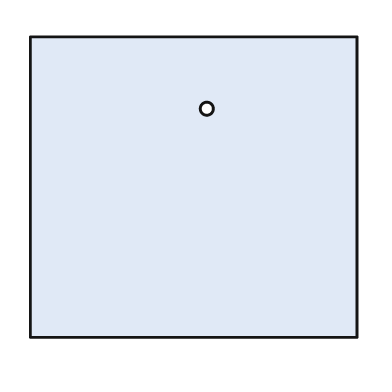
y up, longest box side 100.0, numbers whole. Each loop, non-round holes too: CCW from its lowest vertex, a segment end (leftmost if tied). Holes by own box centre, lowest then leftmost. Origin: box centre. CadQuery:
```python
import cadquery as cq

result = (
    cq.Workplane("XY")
    .moveTo(-50.0, -46.0)
    .lineTo(50.0, -46.0)
    .lineTo(50.0, 46.0)
    .lineTo(-50.0, 46.0)
    .close()
    .moveTo(4.0, 24.0)
    .circle(2.0)
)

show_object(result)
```